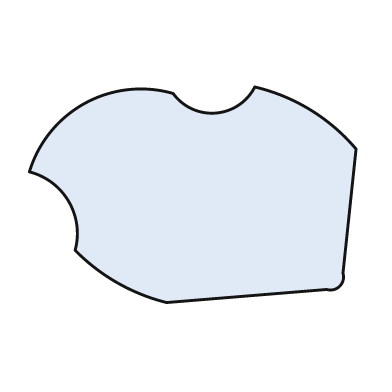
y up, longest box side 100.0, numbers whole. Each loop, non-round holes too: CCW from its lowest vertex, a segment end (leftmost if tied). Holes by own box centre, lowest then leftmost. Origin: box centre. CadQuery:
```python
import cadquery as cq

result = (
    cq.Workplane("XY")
    .moveTo(-8.0, -33.0)
    .lineTo(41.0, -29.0)
    .threePointArc((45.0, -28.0), (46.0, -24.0))
    .lineTo(50.0, 14.0)
    .threePointArc((36.0, 26.0), (19.0, 33.0))
    .threePointArc((7.0, 25.0), (-6.0, 31.0))
    .threePointArc((-33.0, 28.0), (-50.0, 7.0))
    .threePointArc((-38.0, -2.0), (-36.0, -17.0))
    .threePointArc((-23.0, -27.0), (-8.0, -33.0))
    .close()
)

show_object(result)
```